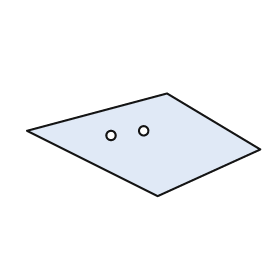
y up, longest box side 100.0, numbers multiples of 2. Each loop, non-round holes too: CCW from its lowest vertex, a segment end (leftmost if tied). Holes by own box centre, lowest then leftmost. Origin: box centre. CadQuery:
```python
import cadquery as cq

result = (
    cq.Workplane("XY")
    .moveTo(6.0, -22.0)
    .lineTo(50.0, -2.0)
    .lineTo(10.0, 22.0)
    .lineTo(-50.0, 6.0)
    .close()
    .moveTo(-14.0, 4.0)
    .circle(2.0)
    .moveTo(0.0, 6.0)
    .circle(2.0)
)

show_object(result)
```